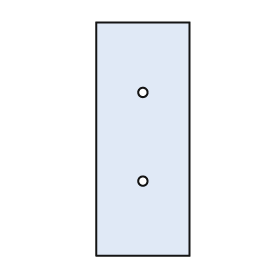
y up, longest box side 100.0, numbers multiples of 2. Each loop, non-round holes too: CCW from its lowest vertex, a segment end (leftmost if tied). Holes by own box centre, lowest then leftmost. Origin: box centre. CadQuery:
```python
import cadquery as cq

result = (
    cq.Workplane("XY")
    .moveTo(-20.0, -50.0)
    .lineTo(20.0, -50.0)
    .lineTo(20.0, 50.0)
    .lineTo(-20.0, 50.0)
    .close()
    .moveTo(0.0, -18.0)
    .circle(2.0)
    .moveTo(0.0, 20.0)
    .circle(2.0)
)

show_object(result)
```